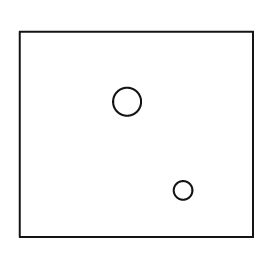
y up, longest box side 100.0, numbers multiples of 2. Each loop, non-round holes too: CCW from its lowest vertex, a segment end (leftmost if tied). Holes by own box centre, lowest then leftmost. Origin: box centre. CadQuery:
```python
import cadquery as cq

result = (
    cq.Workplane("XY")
    .moveTo(-50.0, -44.0)
    .lineTo(50.0, -44.0)
    .lineTo(50.0, 44.0)
    .lineTo(-50.0, 44.0)
    .close()
    .moveTo(20.0, -24.0)
    .circle(4.0)
    .moveTo(-4.0, 14.0)
    .circle(6.0)
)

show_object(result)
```